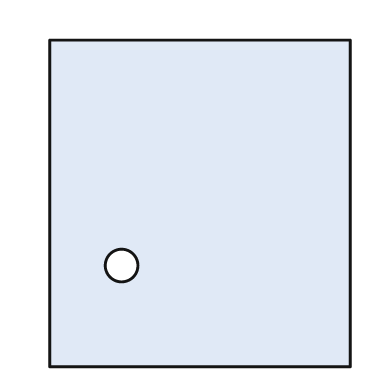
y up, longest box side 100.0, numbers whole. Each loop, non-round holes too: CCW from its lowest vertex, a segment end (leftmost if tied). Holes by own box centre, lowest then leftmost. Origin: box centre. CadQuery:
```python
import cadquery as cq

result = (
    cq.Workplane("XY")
    .moveTo(-46.0, -50.0)
    .lineTo(46.0, -50.0)
    .lineTo(46.0, 50.0)
    .lineTo(-46.0, 50.0)
    .close()
    .moveTo(-24.0, -19.0)
    .circle(5.0)
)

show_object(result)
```